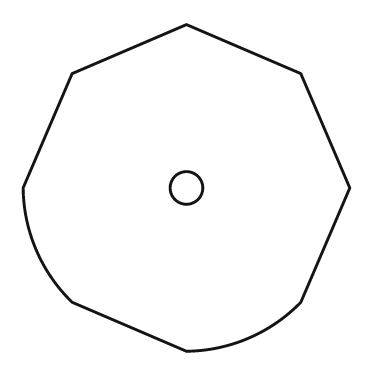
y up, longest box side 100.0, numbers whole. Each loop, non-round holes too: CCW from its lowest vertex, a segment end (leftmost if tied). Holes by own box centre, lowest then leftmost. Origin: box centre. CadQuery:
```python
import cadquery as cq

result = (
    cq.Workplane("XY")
    .moveTo(0.0, -50.0)
    .threePointArc((19.0, -46.0), (35.0, -35.0))
    .lineTo(50.0, 0.0)
    .lineTo(35.0, 35.0)
    .lineTo(0.0, 50.0)
    .lineTo(-35.0, 35.0)
    .lineTo(-50.0, 0.0)
    .threePointArc((-46.0, -19.0), (-35.0, -35.0))
    .close()
    .moveTo(0.0, 0.0)
    .circle(5.0)
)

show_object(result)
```